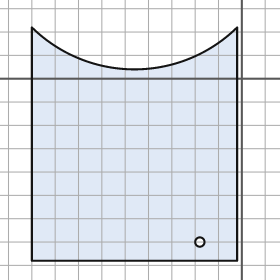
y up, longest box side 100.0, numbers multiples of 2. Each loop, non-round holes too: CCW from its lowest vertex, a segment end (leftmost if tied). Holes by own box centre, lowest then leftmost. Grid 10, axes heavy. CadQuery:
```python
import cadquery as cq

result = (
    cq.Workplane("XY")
    .moveTo(-90.0, -78.0)
    .lineTo(-2.0, -78.0)
    .lineTo(-2.0, 22.0)
    .threePointArc((-46.0, 4.0), (-90.0, 22.0))
    .close()
    .moveTo(-18.0, -70.0)
    .circle(2.0)
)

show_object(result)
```